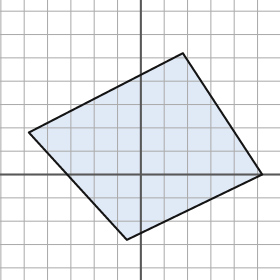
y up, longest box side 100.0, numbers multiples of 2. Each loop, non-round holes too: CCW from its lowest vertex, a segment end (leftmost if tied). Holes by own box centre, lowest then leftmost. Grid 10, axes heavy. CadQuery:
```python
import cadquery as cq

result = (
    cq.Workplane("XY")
    .moveTo(-6.0, -28.0)
    .lineTo(52.0, 0.0)
    .lineTo(18.0, 52.0)
    .lineTo(-48.0, 18.0)
    .close()
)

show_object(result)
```